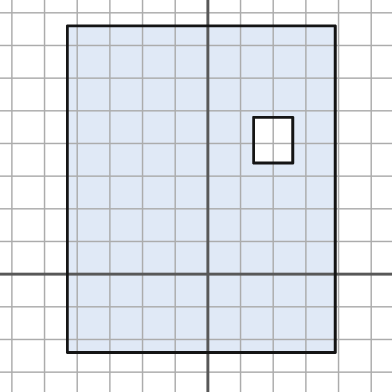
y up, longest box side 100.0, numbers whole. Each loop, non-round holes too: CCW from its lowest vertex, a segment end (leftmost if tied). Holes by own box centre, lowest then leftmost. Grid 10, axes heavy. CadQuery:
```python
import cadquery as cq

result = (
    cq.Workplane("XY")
    .moveTo(-43.0, -24.0)
    .lineTo(39.0, -24.0)
    .lineTo(39.0, 76.0)
    .lineTo(-43.0, 76.0)
    .close()
    .moveTo(14.0, 34.0)
    .lineTo(26.0, 34.0)
    .lineTo(26.0, 48.0)
    .lineTo(14.0, 48.0)
    .close()
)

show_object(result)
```